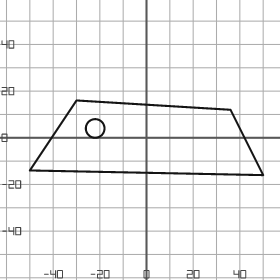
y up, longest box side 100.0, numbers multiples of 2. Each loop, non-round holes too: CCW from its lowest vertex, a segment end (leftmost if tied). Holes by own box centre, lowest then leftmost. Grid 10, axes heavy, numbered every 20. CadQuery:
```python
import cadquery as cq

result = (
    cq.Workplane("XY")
    .moveTo(50.0, -16.0)
    .lineTo(36.0, 12.0)
    .lineTo(-30.0, 16.0)
    .lineTo(-50.0, -14.0)
    .close()
    .moveTo(-22.0, 4.0)
    .circle(4.0)
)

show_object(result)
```